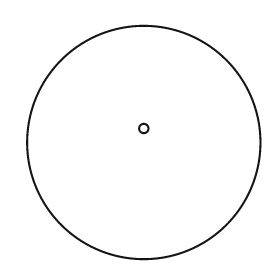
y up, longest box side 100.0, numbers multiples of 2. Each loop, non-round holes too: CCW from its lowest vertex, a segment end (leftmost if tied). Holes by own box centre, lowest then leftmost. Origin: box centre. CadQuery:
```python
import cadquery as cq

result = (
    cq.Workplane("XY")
    .moveTo(0.0, 0.0)
    .circle(50.0)
    .moveTo(0.0, 6.0)
    .circle(2.0)
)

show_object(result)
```